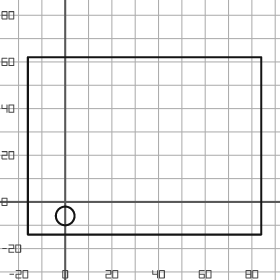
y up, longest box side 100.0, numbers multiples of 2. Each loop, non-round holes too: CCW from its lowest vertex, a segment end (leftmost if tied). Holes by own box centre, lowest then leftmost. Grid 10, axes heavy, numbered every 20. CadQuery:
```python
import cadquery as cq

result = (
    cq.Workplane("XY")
    .moveTo(-16.0, -14.0)
    .lineTo(84.0, -14.0)
    .lineTo(84.0, 62.0)
    .lineTo(-16.0, 62.0)
    .close()
    .moveTo(0.0, -6.0)
    .circle(4.0)
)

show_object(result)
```